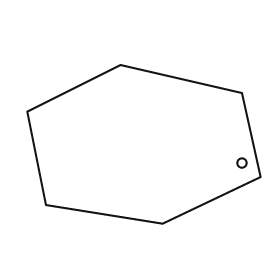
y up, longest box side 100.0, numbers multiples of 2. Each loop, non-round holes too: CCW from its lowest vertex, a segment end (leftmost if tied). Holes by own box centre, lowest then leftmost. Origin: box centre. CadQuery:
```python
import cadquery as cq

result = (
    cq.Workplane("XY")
    .moveTo(8.0, -34.0)
    .lineTo(50.0, -14.0)
    .lineTo(42.0, 22.0)
    .lineTo(-10.0, 34.0)
    .lineTo(-50.0, 14.0)
    .lineTo(-42.0, -26.0)
    .close()
    .moveTo(42.0, -8.0)
    .circle(2.0)
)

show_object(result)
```